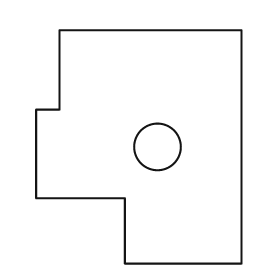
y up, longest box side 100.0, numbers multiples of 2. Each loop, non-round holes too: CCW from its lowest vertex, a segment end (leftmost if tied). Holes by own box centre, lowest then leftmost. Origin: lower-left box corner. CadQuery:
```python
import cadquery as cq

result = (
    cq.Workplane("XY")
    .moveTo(38.0, 0.0)
    .lineTo(88.0, 0.0)
    .lineTo(88.0, 100.0)
    .lineTo(10.0, 100.0)
    .lineTo(10.0, 66.0)
    .lineTo(0.0, 66.0)
    .lineTo(0.0, 28.0)
    .lineTo(38.0, 28.0)
    .close()
    .moveTo(52.0, 50.0)
    .circle(10.0)
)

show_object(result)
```